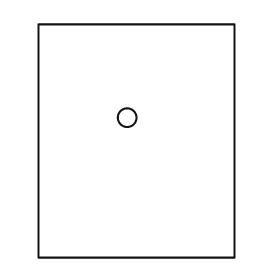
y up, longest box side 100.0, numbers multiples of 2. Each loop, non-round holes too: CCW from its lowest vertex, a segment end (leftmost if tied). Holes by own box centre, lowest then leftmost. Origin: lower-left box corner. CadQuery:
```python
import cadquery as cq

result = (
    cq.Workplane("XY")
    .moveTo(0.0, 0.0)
    .lineTo(84.0, 0.0)
    .lineTo(84.0, 100.0)
    .lineTo(0.0, 100.0)
    .close()
    .moveTo(38.0, 60.0)
    .circle(4.0)
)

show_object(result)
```